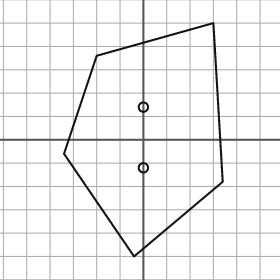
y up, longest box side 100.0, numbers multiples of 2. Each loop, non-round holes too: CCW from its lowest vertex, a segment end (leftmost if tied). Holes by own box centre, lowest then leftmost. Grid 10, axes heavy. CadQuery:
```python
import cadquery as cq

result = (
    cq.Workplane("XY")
    .moveTo(-4.0, -50.0)
    .lineTo(34.0, -18.0)
    .lineTo(30.0, 50.0)
    .lineTo(-20.0, 36.0)
    .lineTo(-34.0, -6.0)
    .close()
    .moveTo(0.0, -12.0)
    .circle(2.0)
    .moveTo(0.0, 14.0)
    .circle(2.0)
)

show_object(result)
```